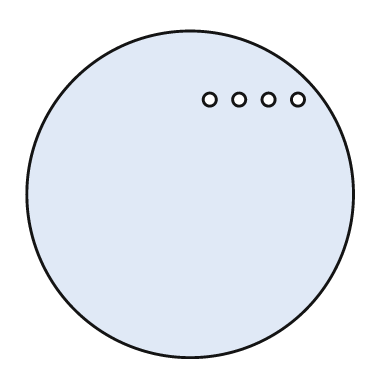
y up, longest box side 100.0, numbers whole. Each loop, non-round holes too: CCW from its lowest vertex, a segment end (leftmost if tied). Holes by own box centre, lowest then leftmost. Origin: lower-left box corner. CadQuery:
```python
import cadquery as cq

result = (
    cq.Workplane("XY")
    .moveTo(50.0, 50.0)
    .circle(50.0)
    .moveTo(56.0, 79.0)
    .circle(2.0)
    .moveTo(65.0, 79.0)
    .circle(2.0)
    .moveTo(74.0, 79.0)
    .circle(2.0)
    .moveTo(83.0, 79.0)
    .circle(2.0)
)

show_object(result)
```